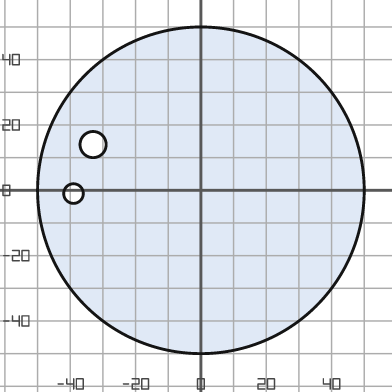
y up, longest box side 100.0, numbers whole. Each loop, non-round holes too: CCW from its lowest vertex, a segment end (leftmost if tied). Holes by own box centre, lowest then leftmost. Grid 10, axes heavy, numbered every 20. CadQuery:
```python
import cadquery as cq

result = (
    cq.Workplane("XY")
    .moveTo(0.0, 0.0)
    .circle(50.0)
    .moveTo(-39.0, -1.0)
    .circle(3.0)
    .moveTo(-33.0, 14.0)
    .circle(4.0)
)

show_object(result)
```